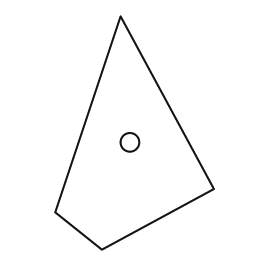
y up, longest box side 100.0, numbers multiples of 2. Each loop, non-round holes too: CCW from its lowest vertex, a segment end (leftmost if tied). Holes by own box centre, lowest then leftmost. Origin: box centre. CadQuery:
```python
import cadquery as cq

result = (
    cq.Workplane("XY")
    .moveTo(-14.0, -50.0)
    .lineTo(34.0, -24.0)
    .lineTo(-6.0, 50.0)
    .lineTo(-34.0, -34.0)
    .close()
    .moveTo(-2.0, -4.0)
    .circle(4.0)
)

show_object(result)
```